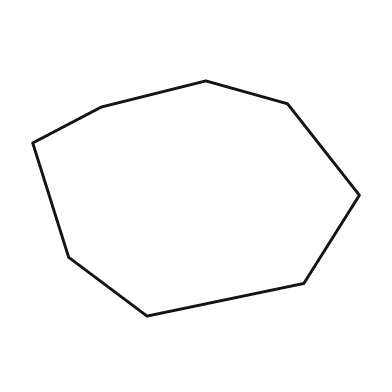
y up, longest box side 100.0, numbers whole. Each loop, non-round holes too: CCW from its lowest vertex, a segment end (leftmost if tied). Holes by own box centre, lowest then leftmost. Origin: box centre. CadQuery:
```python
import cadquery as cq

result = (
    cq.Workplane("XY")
    .moveTo(-15.0, -36.0)
    .lineTo(33.0, -26.0)
    .lineTo(50.0, 1.0)
    .lineTo(28.0, 29.0)
    .lineTo(3.0, 36.0)
    .lineTo(-29.0, 28.0)
    .lineTo(-50.0, 17.0)
    .lineTo(-39.0, -18.0)
    .close()
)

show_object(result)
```